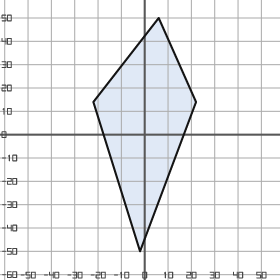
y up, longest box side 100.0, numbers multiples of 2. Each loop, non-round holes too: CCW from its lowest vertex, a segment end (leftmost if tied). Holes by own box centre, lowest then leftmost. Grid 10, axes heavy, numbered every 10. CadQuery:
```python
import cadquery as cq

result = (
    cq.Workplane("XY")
    .moveTo(-2.0, -50.0)
    .lineTo(22.0, 14.0)
    .lineTo(6.0, 50.0)
    .lineTo(-22.0, 14.0)
    .close()
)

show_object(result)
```